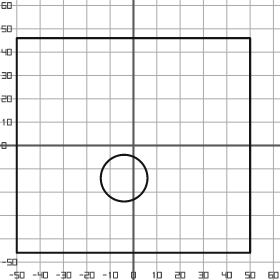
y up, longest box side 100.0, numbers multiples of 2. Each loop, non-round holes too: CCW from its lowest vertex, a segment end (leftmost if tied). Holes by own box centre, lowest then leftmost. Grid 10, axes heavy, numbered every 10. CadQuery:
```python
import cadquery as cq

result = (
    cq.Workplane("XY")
    .moveTo(-50.0, -46.0)
    .lineTo(50.0, -46.0)
    .lineTo(50.0, 46.0)
    .lineTo(-50.0, 46.0)
    .close()
    .moveTo(-4.0, -14.0)
    .circle(10.0)
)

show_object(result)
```